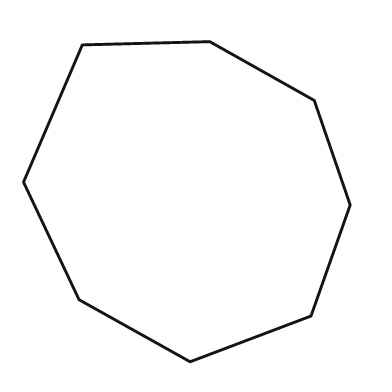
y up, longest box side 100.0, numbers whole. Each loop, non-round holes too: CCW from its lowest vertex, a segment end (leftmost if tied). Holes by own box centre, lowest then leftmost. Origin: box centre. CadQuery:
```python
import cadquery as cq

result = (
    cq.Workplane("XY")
    .moveTo(1.0, -49.0)
    .lineTo(38.0, -35.0)
    .lineTo(50.0, -1.0)
    .lineTo(39.0, 31.0)
    .lineTo(7.0, 49.0)
    .lineTo(-32.0, 48.0)
    .lineTo(-50.0, 6.0)
    .lineTo(-33.0, -30.0)
    .close()
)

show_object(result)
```